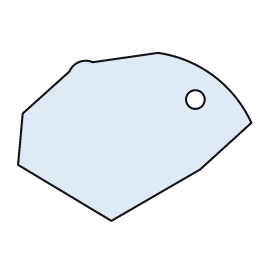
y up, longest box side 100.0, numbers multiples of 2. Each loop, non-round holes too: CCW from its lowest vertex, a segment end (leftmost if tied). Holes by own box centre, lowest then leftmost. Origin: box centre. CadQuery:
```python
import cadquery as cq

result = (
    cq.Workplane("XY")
    .moveTo(-10.0, -36.0)
    .lineTo(28.0, -14.0)
    .lineTo(50.0, 6.0)
    .threePointArc((34.0, 26.0), (10.0, 36.0))
    .lineTo(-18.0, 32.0)
    .threePointArc((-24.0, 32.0), (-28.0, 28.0))
    .lineTo(-48.0, 10.0)
    .lineTo(-50.0, -12.0)
    .close()
    .moveTo(26.0, 16.0)
    .circle(4.0)
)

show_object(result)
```